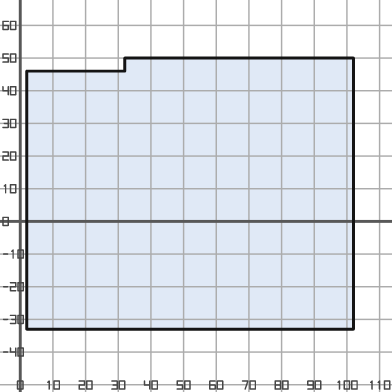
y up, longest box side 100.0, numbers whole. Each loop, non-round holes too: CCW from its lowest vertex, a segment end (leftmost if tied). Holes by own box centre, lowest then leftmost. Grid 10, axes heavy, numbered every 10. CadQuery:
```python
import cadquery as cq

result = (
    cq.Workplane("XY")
    .moveTo(2.0, -33.0)
    .lineTo(102.0, -33.0)
    .lineTo(102.0, 50.0)
    .lineTo(32.0, 50.0)
    .lineTo(32.0, 46.0)
    .lineTo(2.0, 46.0)
    .close()
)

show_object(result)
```